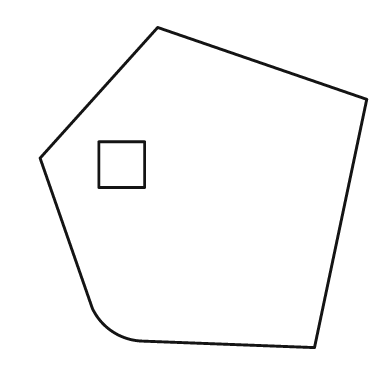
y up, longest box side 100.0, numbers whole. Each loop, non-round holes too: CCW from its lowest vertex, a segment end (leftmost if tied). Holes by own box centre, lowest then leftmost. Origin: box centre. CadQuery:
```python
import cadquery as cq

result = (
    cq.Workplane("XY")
    .moveTo(34.0, -49.0)
    .lineTo(50.0, 27.0)
    .lineTo(-14.0, 49.0)
    .lineTo(-50.0, 9.0)
    .lineTo(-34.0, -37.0)
    .threePointArc((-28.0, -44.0), (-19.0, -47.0))
    .close()
    .moveTo(-32.0, 0.0)
    .lineTo(-18.0, 0.0)
    .lineTo(-18.0, 14.0)
    .lineTo(-32.0, 14.0)
    .close()
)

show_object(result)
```